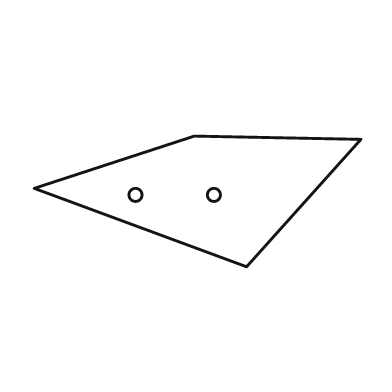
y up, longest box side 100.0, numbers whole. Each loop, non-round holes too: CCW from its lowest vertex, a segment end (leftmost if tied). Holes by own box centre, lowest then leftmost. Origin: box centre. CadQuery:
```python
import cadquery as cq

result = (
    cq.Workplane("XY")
    .moveTo(15.0, -20.0)
    .lineTo(50.0, 19.0)
    .lineTo(-1.0, 20.0)
    .lineTo(-50.0, 4.0)
    .close()
    .moveTo(-19.0, 2.0)
    .circle(2.0)
    .moveTo(5.0, 2.0)
    .circle(2.0)
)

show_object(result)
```